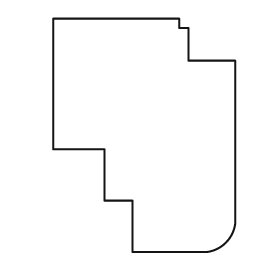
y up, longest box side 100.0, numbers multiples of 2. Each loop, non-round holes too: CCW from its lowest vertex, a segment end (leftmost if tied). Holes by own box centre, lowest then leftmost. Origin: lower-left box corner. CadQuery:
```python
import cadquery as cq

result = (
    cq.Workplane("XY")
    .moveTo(34.0, 0.0)
    .lineTo(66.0, 0.0)
    .threePointArc((74.0, 4.0), (78.0, 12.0))
    .lineTo(78.0, 82.0)
    .lineTo(58.0, 82.0)
    .lineTo(58.0, 96.0)
    .lineTo(54.0, 96.0)
    .lineTo(54.0, 100.0)
    .lineTo(0.0, 100.0)
    .lineTo(0.0, 44.0)
    .lineTo(22.0, 44.0)
    .lineTo(22.0, 22.0)
    .lineTo(34.0, 22.0)
    .close()
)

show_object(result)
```